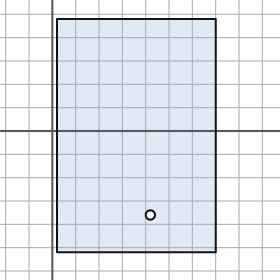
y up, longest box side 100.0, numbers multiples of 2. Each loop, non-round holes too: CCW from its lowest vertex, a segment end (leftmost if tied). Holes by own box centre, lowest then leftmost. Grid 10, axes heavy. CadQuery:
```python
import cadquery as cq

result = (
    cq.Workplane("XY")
    .moveTo(2.0, -52.0)
    .lineTo(70.0, -52.0)
    .lineTo(70.0, 48.0)
    .lineTo(2.0, 48.0)
    .close()
    .moveTo(42.0, -36.0)
    .circle(2.0)
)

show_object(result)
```